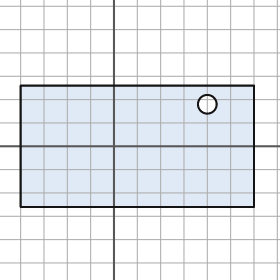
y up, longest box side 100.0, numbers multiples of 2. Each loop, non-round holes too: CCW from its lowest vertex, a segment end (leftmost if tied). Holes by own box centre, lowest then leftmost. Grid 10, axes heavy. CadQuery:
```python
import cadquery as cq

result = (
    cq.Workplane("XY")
    .moveTo(-40.0, -26.0)
    .lineTo(60.0, -26.0)
    .lineTo(60.0, 26.0)
    .lineTo(-40.0, 26.0)
    .close()
    .moveTo(40.0, 18.0)
    .circle(4.0)
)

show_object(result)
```